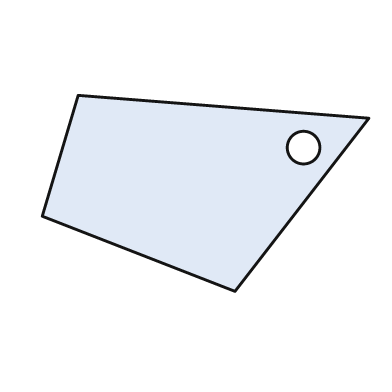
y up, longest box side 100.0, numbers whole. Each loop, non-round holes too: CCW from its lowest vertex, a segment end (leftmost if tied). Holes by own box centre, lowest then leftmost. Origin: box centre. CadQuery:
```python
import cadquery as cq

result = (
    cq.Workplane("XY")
    .moveTo(9.0, -30.0)
    .lineTo(50.0, 23.0)
    .lineTo(-39.0, 30.0)
    .lineTo(-50.0, -7.0)
    .close()
    .moveTo(30.0, 14.0)
    .circle(5.0)
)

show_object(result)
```